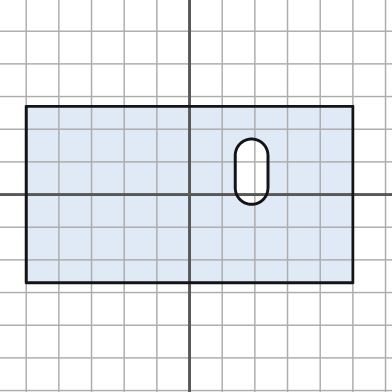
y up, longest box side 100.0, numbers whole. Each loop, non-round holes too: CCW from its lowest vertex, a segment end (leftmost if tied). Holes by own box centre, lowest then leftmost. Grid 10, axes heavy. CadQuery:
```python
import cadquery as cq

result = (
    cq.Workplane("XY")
    .moveTo(-50.0, -27.0)
    .lineTo(50.0, -27.0)
    .lineTo(50.0, 27.0)
    .lineTo(-50.0, 27.0)
    .close()
    .moveTo(14.0, 2.0)
    .threePointArc((19.0, -3.0), (24.0, 2.0))
    .lineTo(24.0, 12.0)
    .threePointArc((19.0, 17.0), (14.0, 12.0))
    .close()
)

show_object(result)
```